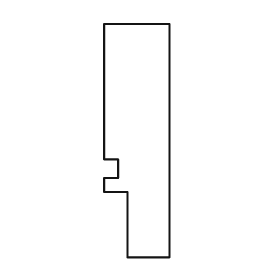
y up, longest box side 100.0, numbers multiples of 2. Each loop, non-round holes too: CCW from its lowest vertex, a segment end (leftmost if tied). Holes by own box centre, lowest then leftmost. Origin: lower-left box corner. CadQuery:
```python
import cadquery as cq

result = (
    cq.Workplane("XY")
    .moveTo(10.0, 0.0)
    .lineTo(28.0, 0.0)
    .lineTo(28.0, 100.0)
    .lineTo(0.0, 100.0)
    .lineTo(0.0, 42.0)
    .lineTo(6.0, 42.0)
    .lineTo(6.0, 34.0)
    .lineTo(0.0, 34.0)
    .lineTo(0.0, 28.0)
    .lineTo(10.0, 28.0)
    .close()
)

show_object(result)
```